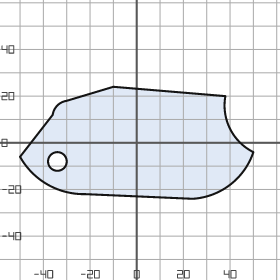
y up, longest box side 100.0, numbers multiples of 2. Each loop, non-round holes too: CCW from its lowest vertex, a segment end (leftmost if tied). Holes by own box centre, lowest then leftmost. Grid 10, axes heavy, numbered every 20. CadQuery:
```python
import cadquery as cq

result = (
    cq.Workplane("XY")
    .moveTo(24.0, -24.0)
    .threePointArc((40.0, -18.0), (50.0, -4.0))
    .threePointArc((40.0, 6.0), (38.0, 20.0))
    .lineTo(-10.0, 24.0)
    .lineTo(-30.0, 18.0)
    .threePointArc((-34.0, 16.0), (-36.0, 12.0))
    .lineTo(-50.0, -6.0)
    .threePointArc((-38.0, -18.0), (-22.0, -22.0))
    .close()
    .moveTo(-34.0, -8.0)
    .circle(4.0)
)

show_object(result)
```